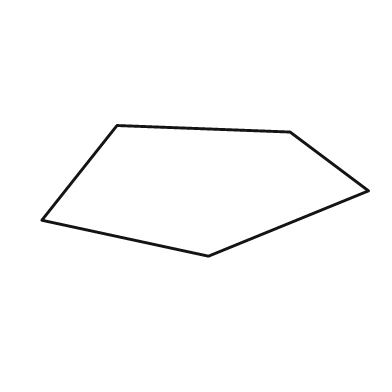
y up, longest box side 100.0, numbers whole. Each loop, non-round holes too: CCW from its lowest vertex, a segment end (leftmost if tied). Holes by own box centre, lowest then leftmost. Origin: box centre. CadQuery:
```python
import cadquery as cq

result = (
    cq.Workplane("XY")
    .moveTo(1.0, -20.0)
    .lineTo(50.0, 0.0)
    .lineTo(26.0, 18.0)
    .lineTo(-27.0, 20.0)
    .lineTo(-50.0, -9.0)
    .close()
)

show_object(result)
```